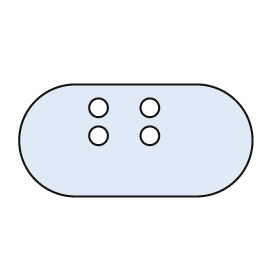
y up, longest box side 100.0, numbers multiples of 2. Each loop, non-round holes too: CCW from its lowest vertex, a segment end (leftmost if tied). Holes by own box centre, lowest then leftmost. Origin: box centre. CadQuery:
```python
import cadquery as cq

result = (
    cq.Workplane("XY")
    .moveTo(-26.0, -24.0)
    .lineTo(26.0, -24.0)
    .threePointArc((50.0, 0.0), (26.0, 24.0))
    .lineTo(-26.0, 24.0)
    .threePointArc((-50.0, 0.0), (-26.0, -24.0))
    .close()
    .moveTo(-16.0, 2.0)
    .circle(4.0)
    .moveTo(6.0, 2.0)
    .circle(4.0)
    .moveTo(-16.0, 14.0)
    .circle(4.0)
    .moveTo(6.0, 14.0)
    .circle(4.0)
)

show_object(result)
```